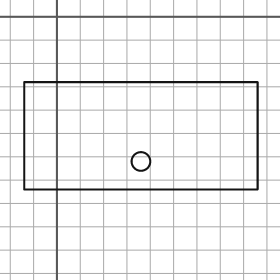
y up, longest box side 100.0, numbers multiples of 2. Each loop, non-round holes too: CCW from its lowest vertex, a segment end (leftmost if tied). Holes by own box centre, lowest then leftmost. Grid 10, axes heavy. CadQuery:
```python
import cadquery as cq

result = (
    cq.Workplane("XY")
    .moveTo(-14.0, -74.0)
    .lineTo(86.0, -74.0)
    .lineTo(86.0, -28.0)
    .lineTo(-14.0, -28.0)
    .close()
    .moveTo(36.0, -62.0)
    .circle(4.0)
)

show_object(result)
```